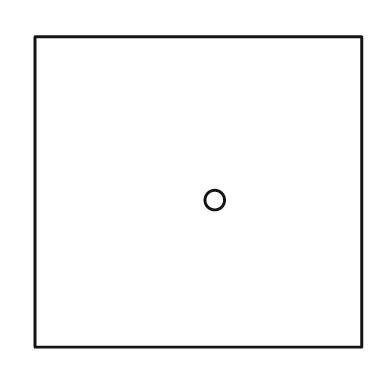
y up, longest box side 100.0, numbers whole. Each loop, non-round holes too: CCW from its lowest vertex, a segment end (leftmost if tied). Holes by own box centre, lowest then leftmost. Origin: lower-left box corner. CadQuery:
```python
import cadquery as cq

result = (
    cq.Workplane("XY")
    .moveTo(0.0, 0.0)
    .lineTo(100.0, 0.0)
    .lineTo(100.0, 95.0)
    .lineTo(0.0, 95.0)
    .close()
    .moveTo(55.0, 45.0)
    .circle(3.0)
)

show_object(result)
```